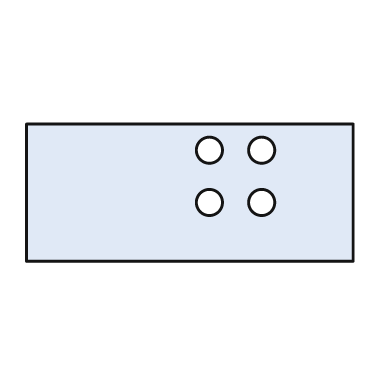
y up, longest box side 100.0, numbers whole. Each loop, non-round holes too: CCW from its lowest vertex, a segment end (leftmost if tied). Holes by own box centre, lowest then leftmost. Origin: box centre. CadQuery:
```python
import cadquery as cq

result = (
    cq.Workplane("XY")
    .moveTo(-50.0, -21.0)
    .lineTo(50.0, -21.0)
    .lineTo(50.0, 21.0)
    .lineTo(-50.0, 21.0)
    .close()
    .moveTo(6.0, -3.0)
    .circle(4.0)
    .moveTo(22.0, -3.0)
    .circle(4.0)
    .moveTo(6.0, 13.0)
    .circle(4.0)
    .moveTo(22.0, 13.0)
    .circle(4.0)
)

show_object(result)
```